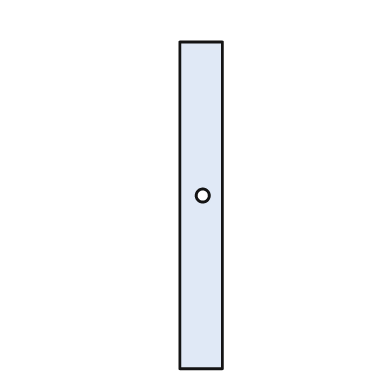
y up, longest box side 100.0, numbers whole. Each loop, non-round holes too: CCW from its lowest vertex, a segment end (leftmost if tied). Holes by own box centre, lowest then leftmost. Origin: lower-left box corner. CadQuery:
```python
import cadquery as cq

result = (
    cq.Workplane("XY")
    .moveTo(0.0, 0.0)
    .lineTo(13.0, 0.0)
    .lineTo(13.0, 100.0)
    .lineTo(0.0, 100.0)
    .close()
    .moveTo(7.0, 53.0)
    .circle(2.0)
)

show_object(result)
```